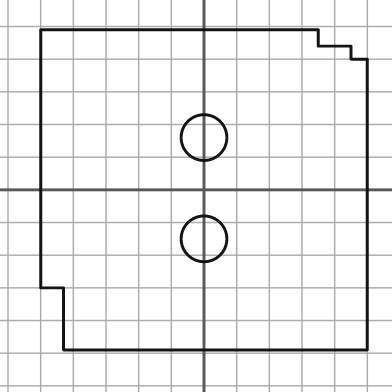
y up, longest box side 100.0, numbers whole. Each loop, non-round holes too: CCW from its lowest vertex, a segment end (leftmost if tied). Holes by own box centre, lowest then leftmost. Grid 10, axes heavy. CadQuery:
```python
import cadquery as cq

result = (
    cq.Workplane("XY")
    .moveTo(-43.0, -49.0)
    .lineTo(50.0, -49.0)
    .lineTo(50.0, 40.0)
    .lineTo(45.0, 40.0)
    .lineTo(45.0, 44.0)
    .lineTo(35.0, 44.0)
    .lineTo(35.0, 49.0)
    .lineTo(-50.0, 49.0)
    .lineTo(-50.0, -30.0)
    .lineTo(-43.0, -30.0)
    .close()
    .moveTo(0.0, -15.0)
    .circle(7.0)
    .moveTo(0.0, 16.0)
    .circle(7.0)
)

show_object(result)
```